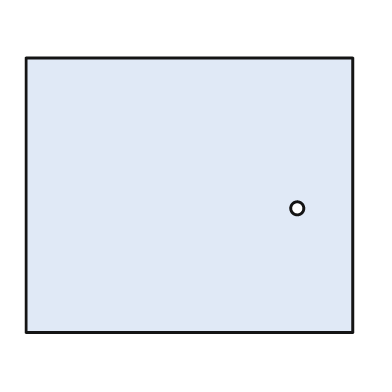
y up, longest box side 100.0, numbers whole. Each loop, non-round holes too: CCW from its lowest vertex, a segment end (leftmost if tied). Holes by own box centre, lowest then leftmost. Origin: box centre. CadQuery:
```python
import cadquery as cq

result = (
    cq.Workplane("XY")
    .moveTo(-50.0, -42.0)
    .lineTo(50.0, -42.0)
    .lineTo(50.0, 42.0)
    .lineTo(-50.0, 42.0)
    .close()
    .moveTo(33.0, -4.0)
    .circle(2.0)
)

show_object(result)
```